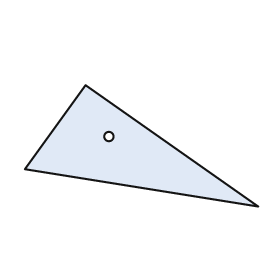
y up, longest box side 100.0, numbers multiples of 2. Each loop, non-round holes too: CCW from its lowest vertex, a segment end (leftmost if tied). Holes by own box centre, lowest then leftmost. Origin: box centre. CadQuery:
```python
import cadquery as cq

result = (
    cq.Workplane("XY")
    .moveTo(50.0, -26.0)
    .lineTo(-24.0, 26.0)
    .lineTo(-50.0, -10.0)
    .close()
    .moveTo(-14.0, 4.0)
    .circle(2.0)
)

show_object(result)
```